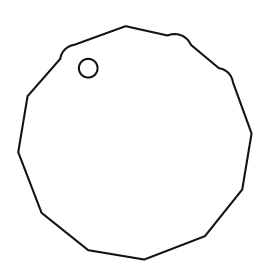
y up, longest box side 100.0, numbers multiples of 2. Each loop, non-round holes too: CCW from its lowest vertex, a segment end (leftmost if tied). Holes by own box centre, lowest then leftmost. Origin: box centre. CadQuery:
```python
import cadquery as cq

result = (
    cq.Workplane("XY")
    .moveTo(4.0, -50.0)
    .lineTo(30.0, -40.0)
    .lineTo(46.0, -20.0)
    .lineTo(50.0, 4.0)
    .lineTo(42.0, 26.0)
    .threePointArc((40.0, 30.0), (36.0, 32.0))
    .lineTo(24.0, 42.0)
    .threePointArc((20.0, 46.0), (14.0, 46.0))
    .lineTo(-4.0, 50.0)
    .lineTo(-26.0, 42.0)
    .threePointArc((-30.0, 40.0), (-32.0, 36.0))
    .lineTo(-46.0, 20.0)
    .lineTo(-50.0, -4.0)
    .lineTo(-40.0, -30.0)
    .lineTo(-20.0, -46.0)
    .close()
    .moveTo(-20.0, 32.0)
    .circle(4.0)
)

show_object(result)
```